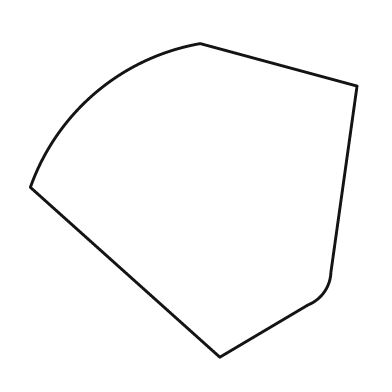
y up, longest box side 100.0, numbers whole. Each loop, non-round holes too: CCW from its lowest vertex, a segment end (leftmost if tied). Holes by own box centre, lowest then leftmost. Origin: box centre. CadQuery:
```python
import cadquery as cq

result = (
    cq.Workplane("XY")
    .moveTo(8.0, -48.0)
    .lineTo(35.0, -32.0)
    .threePointArc((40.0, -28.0), (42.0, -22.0))
    .lineTo(50.0, 35.0)
    .lineTo(2.0, 48.0)
    .threePointArc((-30.0, 33.0), (-50.0, 4.0))
    .close()
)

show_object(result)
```